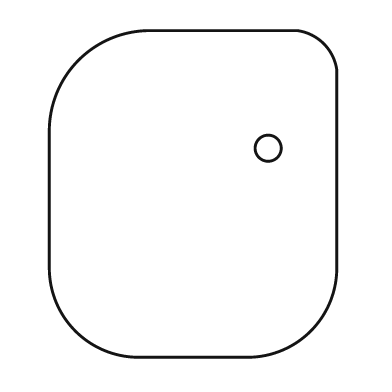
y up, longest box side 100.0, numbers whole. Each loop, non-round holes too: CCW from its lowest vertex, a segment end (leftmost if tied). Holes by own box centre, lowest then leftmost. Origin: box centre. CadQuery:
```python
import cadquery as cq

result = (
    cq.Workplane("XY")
    .moveTo(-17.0, -50.0)
    .lineTo(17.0, -50.0)
    .threePointArc((36.0, -42.0), (44.0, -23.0))
    .lineTo(44.0, 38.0)
    .threePointArc((40.0, 46.0), (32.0, 50.0))
    .lineTo(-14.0, 50.0)
    .threePointArc((-35.0, 41.0), (-44.0, 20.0))
    .lineTo(-44.0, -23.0)
    .threePointArc((-36.0, -42.0), (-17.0, -50.0))
    .close()
    .moveTo(23.0, 14.0)
    .circle(4.0)
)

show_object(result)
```